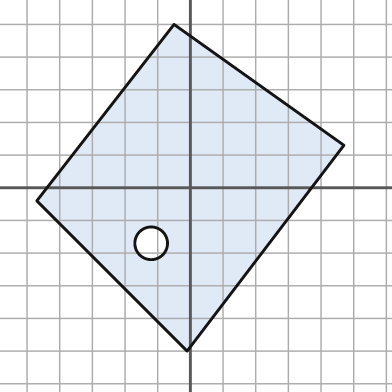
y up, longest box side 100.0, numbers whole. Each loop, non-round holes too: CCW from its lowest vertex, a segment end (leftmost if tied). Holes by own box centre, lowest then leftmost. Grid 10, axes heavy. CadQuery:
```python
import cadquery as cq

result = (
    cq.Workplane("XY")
    .moveTo(-1.0, -50.0)
    .lineTo(47.0, 13.0)
    .lineTo(-5.0, 50.0)
    .lineTo(-47.0, -4.0)
    .close()
    .moveTo(-12.0, -17.0)
    .circle(5.0)
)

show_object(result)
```